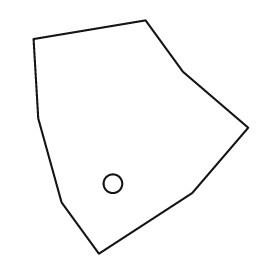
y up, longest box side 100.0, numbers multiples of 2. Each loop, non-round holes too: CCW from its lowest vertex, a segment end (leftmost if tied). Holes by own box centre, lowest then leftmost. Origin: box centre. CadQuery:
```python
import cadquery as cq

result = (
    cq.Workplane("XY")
    .moveTo(-18.0, -50.0)
    .lineTo(22.0, -24.0)
    .lineTo(46.0, 4.0)
    .lineTo(18.0, 28.0)
    .lineTo(2.0, 50.0)
    .lineTo(-46.0, 42.0)
    .lineTo(-44.0, 8.0)
    .lineTo(-34.0, -28.0)
    .close()
    .moveTo(-12.0, -20.0)
    .circle(4.0)
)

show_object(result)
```